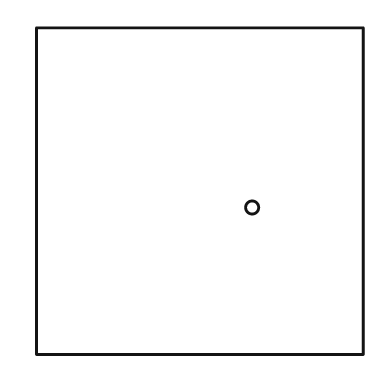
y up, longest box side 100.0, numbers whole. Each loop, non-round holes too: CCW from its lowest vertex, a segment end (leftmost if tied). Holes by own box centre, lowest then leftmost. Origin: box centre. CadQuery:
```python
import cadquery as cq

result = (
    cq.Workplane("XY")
    .moveTo(-50.0, -50.0)
    .lineTo(50.0, -50.0)
    .lineTo(50.0, 50.0)
    .lineTo(-50.0, 50.0)
    .close()
    .moveTo(16.0, -5.0)
    .circle(2.0)
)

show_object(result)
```